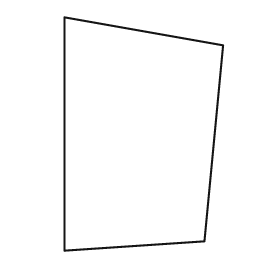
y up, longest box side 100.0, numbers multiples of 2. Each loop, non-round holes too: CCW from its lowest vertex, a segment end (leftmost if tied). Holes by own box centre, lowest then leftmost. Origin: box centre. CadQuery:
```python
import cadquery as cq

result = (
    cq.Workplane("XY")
    .moveTo(-34.0, -50.0)
    .lineTo(26.0, -46.0)
    .lineTo(34.0, 38.0)
    .lineTo(-34.0, 50.0)
    .close()
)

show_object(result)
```